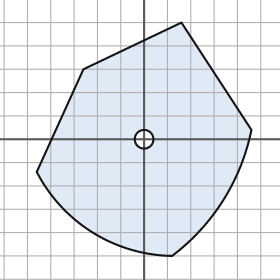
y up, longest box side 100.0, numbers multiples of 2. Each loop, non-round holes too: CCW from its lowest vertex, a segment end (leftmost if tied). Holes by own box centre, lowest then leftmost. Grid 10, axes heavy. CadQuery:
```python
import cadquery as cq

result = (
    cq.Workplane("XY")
    .moveTo(12.0, -50.0)
    .threePointArc((34.0, -26.0), (46.0, 4.0))
    .lineTo(16.0, 50.0)
    .lineTo(-26.0, 30.0)
    .lineTo(-46.0, -14.0)
    .threePointArc((-22.0, -40.0), (12.0, -50.0))
    .close()
    .moveTo(0.0, 0.0)
    .circle(4.0)
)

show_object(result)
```